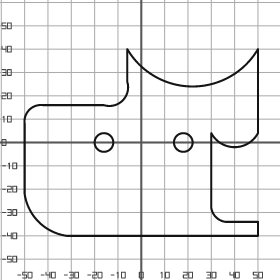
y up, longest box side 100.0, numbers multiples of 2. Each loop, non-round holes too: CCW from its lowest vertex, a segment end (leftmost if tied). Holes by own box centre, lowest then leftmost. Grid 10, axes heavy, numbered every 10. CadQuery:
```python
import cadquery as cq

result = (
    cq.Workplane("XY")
    .moveTo(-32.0, -40.0)
    .lineTo(50.0, -40.0)
    .lineTo(50.0, -34.0)
    .lineTo(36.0, -34.0)
    .threePointArc((32.0, -32.0), (30.0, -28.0))
    .lineTo(30.0, 4.0)
    .threePointArc((40.0, -2.0), (50.0, 4.0))
    .lineTo(50.0, 40.0)
    .threePointArc((22.0, 24.0), (-6.0, 40.0))
    .lineTo(-6.0, 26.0)
    .threePointArc((-8.0, 18.0), (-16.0, 16.0))
    .lineTo(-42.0, 16.0)
    .threePointArc((-48.0, 14.0), (-50.0, 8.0))
    .lineTo(-50.0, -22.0)
    .threePointArc((-44.0, -34.0), (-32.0, -40.0))
    .close()
    .moveTo(-16.0, 0.0)
    .circle(4.0)
    .moveTo(18.0, 0.0)
    .circle(4.0)
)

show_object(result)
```